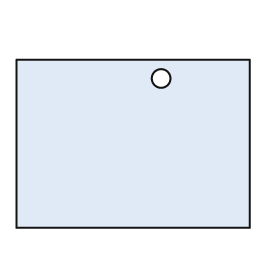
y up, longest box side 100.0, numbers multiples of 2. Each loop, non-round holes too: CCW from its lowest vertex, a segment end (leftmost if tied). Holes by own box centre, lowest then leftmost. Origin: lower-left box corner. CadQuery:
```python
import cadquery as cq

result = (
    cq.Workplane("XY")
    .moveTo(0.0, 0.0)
    .lineTo(100.0, 0.0)
    .lineTo(100.0, 72.0)
    .lineTo(0.0, 72.0)
    .close()
    .moveTo(62.0, 64.0)
    .circle(4.0)
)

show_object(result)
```